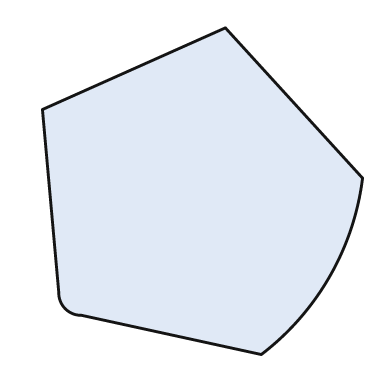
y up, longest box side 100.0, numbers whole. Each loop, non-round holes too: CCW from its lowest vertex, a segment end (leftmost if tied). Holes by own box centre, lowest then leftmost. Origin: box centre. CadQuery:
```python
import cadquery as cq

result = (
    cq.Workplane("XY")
    .moveTo(18.0, -50.0)
    .threePointArc((39.0, -26.0), (49.0, 4.0))
    .lineTo(7.0, 50.0)
    .lineTo(-49.0, 25.0)
    .lineTo(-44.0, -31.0)
    .threePointArc((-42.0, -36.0), (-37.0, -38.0))
    .close()
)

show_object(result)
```